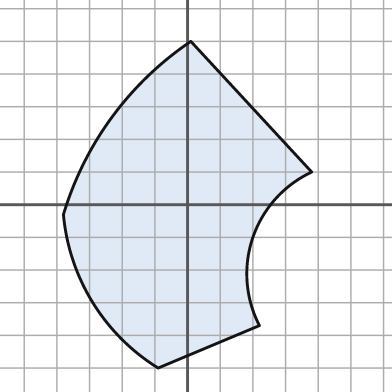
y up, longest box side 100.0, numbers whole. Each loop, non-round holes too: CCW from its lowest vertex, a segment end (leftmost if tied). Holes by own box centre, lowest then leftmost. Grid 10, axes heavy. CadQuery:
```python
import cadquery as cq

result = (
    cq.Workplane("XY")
    .moveTo(-9.0, -50.0)
    .lineTo(22.0, -37.0)
    .threePointArc((20.0, -10.0), (38.0, 10.0))
    .lineTo(1.0, 50.0)
    .threePointArc((-23.0, 27.0), (-38.0, -3.0))
    .threePointArc((-29.0, -30.0), (-9.0, -50.0))
    .close()
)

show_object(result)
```